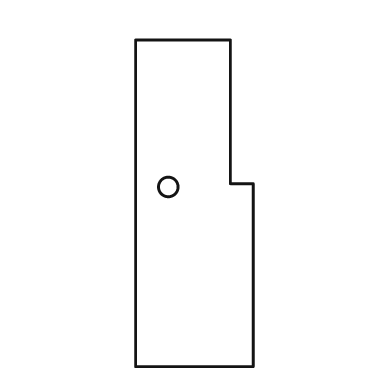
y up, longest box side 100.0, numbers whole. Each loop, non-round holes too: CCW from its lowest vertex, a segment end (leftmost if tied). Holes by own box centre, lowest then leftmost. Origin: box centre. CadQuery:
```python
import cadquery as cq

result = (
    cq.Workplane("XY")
    .moveTo(-18.0, -50.0)
    .lineTo(18.0, -50.0)
    .lineTo(18.0, 6.0)
    .lineTo(11.0, 6.0)
    .lineTo(11.0, 50.0)
    .lineTo(-18.0, 50.0)
    .close()
    .moveTo(-8.0, 5.0)
    .circle(3.0)
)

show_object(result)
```